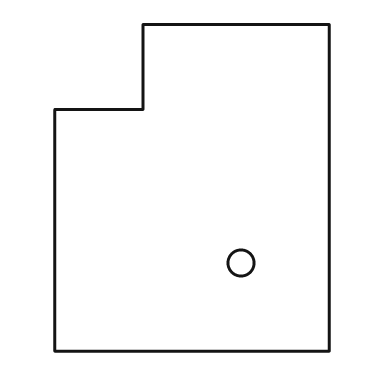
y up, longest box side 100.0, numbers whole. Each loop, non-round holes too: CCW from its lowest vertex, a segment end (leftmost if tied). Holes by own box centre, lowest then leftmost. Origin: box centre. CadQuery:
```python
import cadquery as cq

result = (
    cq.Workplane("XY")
    .moveTo(-42.0, -50.0)
    .lineTo(42.0, -50.0)
    .lineTo(42.0, 50.0)
    .lineTo(-15.0, 50.0)
    .lineTo(-15.0, 24.0)
    .lineTo(-42.0, 24.0)
    .close()
    .moveTo(15.0, -23.0)
    .circle(4.0)
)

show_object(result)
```